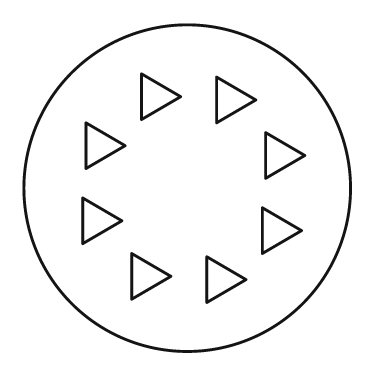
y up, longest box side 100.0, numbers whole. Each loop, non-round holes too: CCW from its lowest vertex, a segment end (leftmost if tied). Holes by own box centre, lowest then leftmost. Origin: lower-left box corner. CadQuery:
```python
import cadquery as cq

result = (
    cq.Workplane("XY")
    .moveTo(50.0, 50.0)
    .circle(50.0)
    .moveTo(56.0, 15.0)
    .lineTo(68.0, 22.0)
    .lineTo(56.0, 29.0)
    .close()
    .moveTo(33.0, 16.0)
    .lineTo(45.0, 23.0)
    .lineTo(33.0, 30.0)
    .close()
    .moveTo(73.0, 30.0)
    .lineTo(85.0, 37.0)
    .lineTo(73.0, 44.0)
    .close()
    .moveTo(18.0, 33.0)
    .lineTo(30.0, 40.0)
    .lineTo(18.0, 47.0)
    .close()
    .moveTo(74.0, 53.0)
    .lineTo(86.0, 60.0)
    .lineTo(74.0, 67.0)
    .close()
    .moveTo(19.0, 56.0)
    .lineTo(31.0, 63.0)
    .lineTo(19.0, 70.0)
    .close()
    .moveTo(59.0, 70.0)
    .lineTo(71.0, 77.0)
    .lineTo(59.0, 84.0)
    .close()
    .moveTo(36.0, 71.0)
    .lineTo(48.0, 78.0)
    .lineTo(36.0, 85.0)
    .close()
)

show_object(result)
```